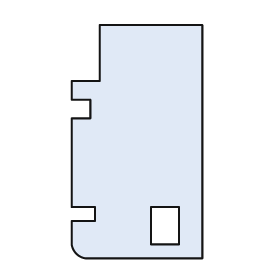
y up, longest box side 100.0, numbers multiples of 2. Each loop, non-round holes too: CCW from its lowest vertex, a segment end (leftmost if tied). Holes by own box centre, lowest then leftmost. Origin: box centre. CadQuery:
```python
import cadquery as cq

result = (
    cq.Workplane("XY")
    .moveTo(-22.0, -50.0)
    .lineTo(28.0, -50.0)
    .lineTo(28.0, 50.0)
    .lineTo(-16.0, 50.0)
    .lineTo(-16.0, 26.0)
    .lineTo(-28.0, 26.0)
    .lineTo(-28.0, 18.0)
    .lineTo(-20.0, 18.0)
    .lineTo(-20.0, 10.0)
    .lineTo(-28.0, 10.0)
    .lineTo(-28.0, -28.0)
    .lineTo(-18.0, -28.0)
    .lineTo(-18.0, -34.0)
    .lineTo(-28.0, -34.0)
    .lineTo(-28.0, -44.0)
    .threePointArc((-26.0, -48.0), (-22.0, -50.0))
    .close()
    .moveTo(6.0, -44.0)
    .lineTo(18.0, -44.0)
    .lineTo(18.0, -28.0)
    .lineTo(6.0, -28.0)
    .close()
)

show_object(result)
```